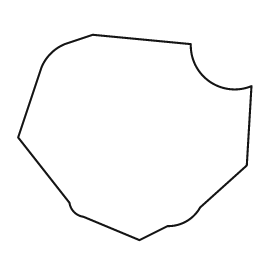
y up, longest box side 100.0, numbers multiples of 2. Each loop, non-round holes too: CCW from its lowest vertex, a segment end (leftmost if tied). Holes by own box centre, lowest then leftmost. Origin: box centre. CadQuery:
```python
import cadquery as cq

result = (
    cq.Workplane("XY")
    .moveTo(2.0, -44.0)
    .lineTo(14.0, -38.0)
    .threePointArc((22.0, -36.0), (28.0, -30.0))
    .lineTo(48.0, -12.0)
    .lineTo(50.0, 22.0)
    .threePointArc((32.0, 24.0), (24.0, 40.0))
    .lineTo(-18.0, 44.0)
    .lineTo(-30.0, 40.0)
    .threePointArc((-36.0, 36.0), (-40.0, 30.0))
    .lineTo(-50.0, 0.0)
    .lineTo(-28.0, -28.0)
    .threePointArc((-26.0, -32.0), (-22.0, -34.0))
    .close()
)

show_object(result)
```